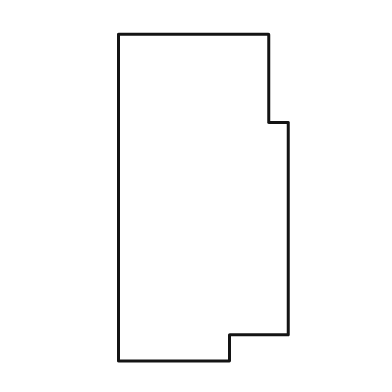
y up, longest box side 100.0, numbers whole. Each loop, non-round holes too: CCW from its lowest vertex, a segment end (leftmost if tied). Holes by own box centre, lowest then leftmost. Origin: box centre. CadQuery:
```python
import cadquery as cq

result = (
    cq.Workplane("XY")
    .moveTo(-26.0, -50.0)
    .lineTo(8.0, -50.0)
    .lineTo(8.0, -42.0)
    .lineTo(26.0, -42.0)
    .lineTo(26.0, 23.0)
    .lineTo(20.0, 23.0)
    .lineTo(20.0, 50.0)
    .lineTo(-26.0, 50.0)
    .close()
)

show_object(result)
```